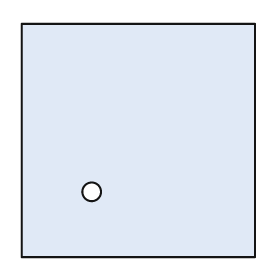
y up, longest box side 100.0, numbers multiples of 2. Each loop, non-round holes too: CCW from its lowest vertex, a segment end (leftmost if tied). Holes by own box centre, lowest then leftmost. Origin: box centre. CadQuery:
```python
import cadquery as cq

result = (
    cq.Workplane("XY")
    .moveTo(-50.0, -50.0)
    .lineTo(50.0, -50.0)
    .lineTo(50.0, 50.0)
    .lineTo(-50.0, 50.0)
    .close()
    .moveTo(-20.0, -22.0)
    .circle(4.0)
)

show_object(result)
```